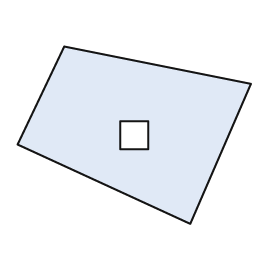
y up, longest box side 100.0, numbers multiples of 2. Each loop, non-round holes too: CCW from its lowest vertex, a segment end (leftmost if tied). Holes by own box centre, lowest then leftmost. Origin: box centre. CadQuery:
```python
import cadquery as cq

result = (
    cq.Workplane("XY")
    .moveTo(24.0, -38.0)
    .lineTo(50.0, 22.0)
    .lineTo(-30.0, 38.0)
    .lineTo(-50.0, -4.0)
    .close()
    .moveTo(-6.0, -6.0)
    .lineTo(6.0, -6.0)
    .lineTo(6.0, 6.0)
    .lineTo(-6.0, 6.0)
    .close()
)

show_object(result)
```